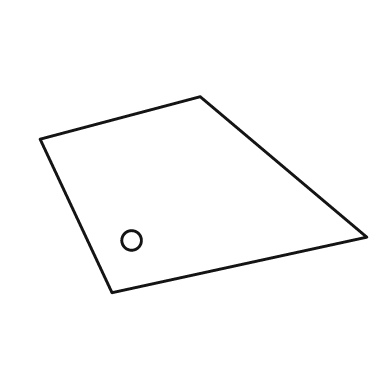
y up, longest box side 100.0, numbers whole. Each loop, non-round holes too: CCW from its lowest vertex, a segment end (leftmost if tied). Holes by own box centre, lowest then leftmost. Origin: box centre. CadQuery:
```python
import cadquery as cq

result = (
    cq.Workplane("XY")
    .moveTo(-28.0, -30.0)
    .lineTo(50.0, -13.0)
    .lineTo(-1.0, 30.0)
    .lineTo(-50.0, 17.0)
    .close()
    .moveTo(-22.0, -14.0)
    .circle(3.0)
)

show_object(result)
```